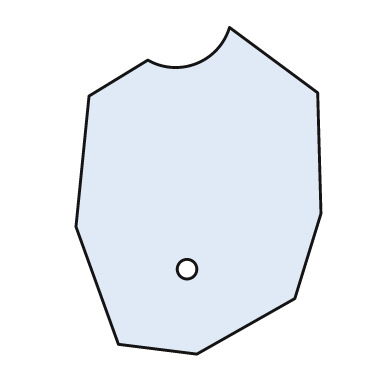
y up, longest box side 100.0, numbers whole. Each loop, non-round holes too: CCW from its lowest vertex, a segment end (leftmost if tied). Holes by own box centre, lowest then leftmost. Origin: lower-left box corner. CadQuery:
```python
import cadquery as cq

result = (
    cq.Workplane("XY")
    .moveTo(37.0, 0.0)
    .lineTo(67.0, 17.0)
    .lineTo(75.0, 43.0)
    .lineTo(74.0, 80.0)
    .lineTo(47.0, 100.0)
    .threePointArc((37.0, 89.0), (22.0, 90.0))
    .lineTo(4.0, 79.0)
    .lineTo(0.0, 39.0)
    .lineTo(13.0, 3.0)
    .close()
    .moveTo(34.0, 26.0)
    .circle(3.0)
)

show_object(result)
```